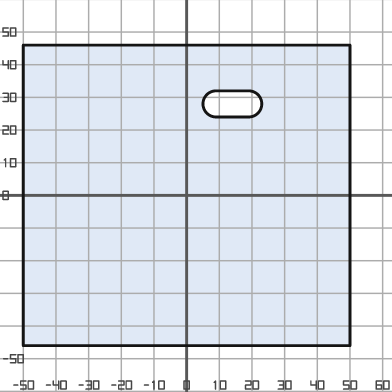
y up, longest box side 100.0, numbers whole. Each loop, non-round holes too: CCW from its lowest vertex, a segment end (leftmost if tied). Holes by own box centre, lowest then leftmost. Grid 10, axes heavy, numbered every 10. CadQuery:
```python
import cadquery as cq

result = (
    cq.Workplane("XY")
    .moveTo(-50.0, -46.0)
    .lineTo(50.0, -46.0)
    .lineTo(50.0, 46.0)
    .lineTo(-50.0, 46.0)
    .close()
    .moveTo(9.0, 24.0)
    .lineTo(19.0, 24.0)
    .threePointArc((23.0, 28.0), (19.0, 32.0))
    .lineTo(9.0, 32.0)
    .threePointArc((5.0, 28.0), (9.0, 24.0))
    .close()
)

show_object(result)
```